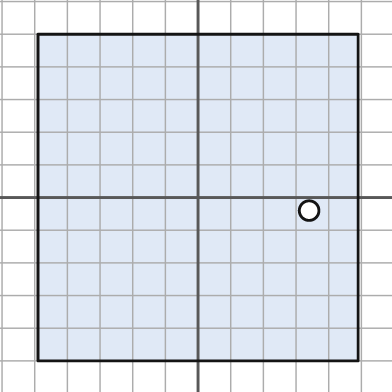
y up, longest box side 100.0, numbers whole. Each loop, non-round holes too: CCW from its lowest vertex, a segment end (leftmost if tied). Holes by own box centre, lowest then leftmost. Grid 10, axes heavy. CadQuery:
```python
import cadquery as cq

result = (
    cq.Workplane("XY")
    .moveTo(-49.0, -50.0)
    .lineTo(49.0, -50.0)
    .lineTo(49.0, 50.0)
    .lineTo(-49.0, 50.0)
    .close()
    .moveTo(34.0, -4.0)
    .circle(3.0)
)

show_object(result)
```